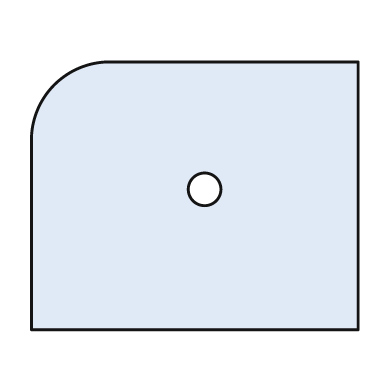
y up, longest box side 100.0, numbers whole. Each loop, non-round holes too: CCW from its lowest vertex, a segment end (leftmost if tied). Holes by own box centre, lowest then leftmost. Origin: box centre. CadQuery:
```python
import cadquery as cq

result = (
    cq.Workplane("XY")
    .moveTo(-50.0, -41.0)
    .lineTo(50.0, -41.0)
    .lineTo(50.0, 41.0)
    .lineTo(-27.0, 41.0)
    .threePointArc((-43.0, 34.0), (-50.0, 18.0))
    .close()
    .moveTo(3.0, 2.0)
    .circle(5.0)
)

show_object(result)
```